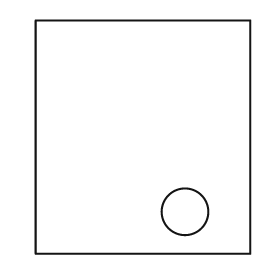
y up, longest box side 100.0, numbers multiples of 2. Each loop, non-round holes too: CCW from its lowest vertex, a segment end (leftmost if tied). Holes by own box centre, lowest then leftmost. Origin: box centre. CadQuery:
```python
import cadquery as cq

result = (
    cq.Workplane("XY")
    .moveTo(-46.0, -50.0)
    .lineTo(46.0, -50.0)
    .lineTo(46.0, 50.0)
    .lineTo(-46.0, 50.0)
    .close()
    .moveTo(18.0, -32.0)
    .circle(10.0)
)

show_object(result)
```